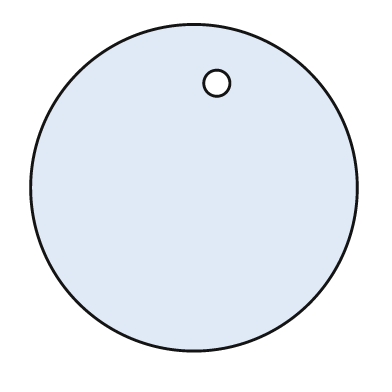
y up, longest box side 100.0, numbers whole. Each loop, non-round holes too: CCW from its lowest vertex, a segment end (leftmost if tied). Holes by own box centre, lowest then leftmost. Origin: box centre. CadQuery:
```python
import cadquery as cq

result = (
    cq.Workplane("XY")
    .moveTo(0.0, 0.0)
    .circle(50.0)
    .moveTo(7.0, 32.0)
    .circle(4.0)
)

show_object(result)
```